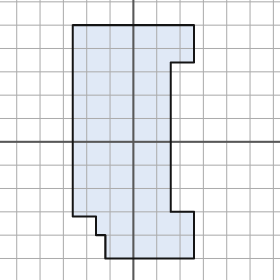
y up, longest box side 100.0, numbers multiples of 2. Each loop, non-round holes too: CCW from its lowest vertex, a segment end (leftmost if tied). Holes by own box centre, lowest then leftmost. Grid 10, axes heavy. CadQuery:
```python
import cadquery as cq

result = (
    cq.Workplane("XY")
    .moveTo(-12.0, -50.0)
    .lineTo(26.0, -50.0)
    .lineTo(26.0, -30.0)
    .lineTo(16.0, -30.0)
    .lineTo(16.0, 34.0)
    .lineTo(26.0, 34.0)
    .lineTo(26.0, 50.0)
    .lineTo(-26.0, 50.0)
    .lineTo(-26.0, -32.0)
    .lineTo(-16.0, -32.0)
    .lineTo(-16.0, -40.0)
    .lineTo(-12.0, -40.0)
    .close()
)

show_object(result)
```